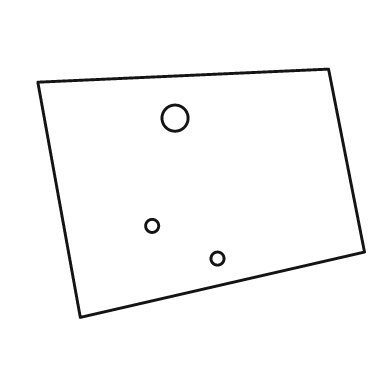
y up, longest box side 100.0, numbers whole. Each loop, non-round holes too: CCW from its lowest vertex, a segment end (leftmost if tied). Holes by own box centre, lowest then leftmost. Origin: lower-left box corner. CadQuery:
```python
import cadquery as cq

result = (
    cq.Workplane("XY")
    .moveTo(13.0, 0.0)
    .lineTo(100.0, 20.0)
    .lineTo(89.0, 76.0)
    .lineTo(0.0, 72.0)
    .close()
    .moveTo(55.0, 18.0)
    .circle(2.0)
    .moveTo(35.0, 28.0)
    .circle(2.0)
    .moveTo(42.0, 61.0)
    .circle(4.0)
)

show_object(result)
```